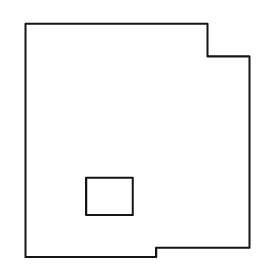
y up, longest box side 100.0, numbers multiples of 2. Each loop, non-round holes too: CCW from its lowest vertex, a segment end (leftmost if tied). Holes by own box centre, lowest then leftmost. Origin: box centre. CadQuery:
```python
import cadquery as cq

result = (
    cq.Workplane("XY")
    .moveTo(-48.0, -50.0)
    .lineTo(8.0, -50.0)
    .lineTo(8.0, -46.0)
    .lineTo(48.0, -46.0)
    .lineTo(48.0, 36.0)
    .lineTo(30.0, 36.0)
    .lineTo(30.0, 50.0)
    .lineTo(-48.0, 50.0)
    .close()
    .moveTo(-22.0, -32.0)
    .lineTo(-2.0, -32.0)
    .lineTo(-2.0, -16.0)
    .lineTo(-22.0, -16.0)
    .close()
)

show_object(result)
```